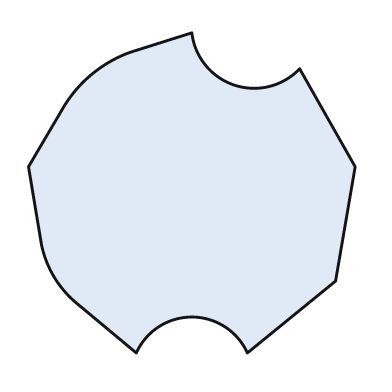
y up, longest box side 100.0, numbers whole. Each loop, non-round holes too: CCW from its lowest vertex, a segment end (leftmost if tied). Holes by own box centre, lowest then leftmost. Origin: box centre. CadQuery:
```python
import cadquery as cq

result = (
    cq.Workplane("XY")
    .moveTo(-17.0, -49.0)
    .threePointArc((0.0, -38.0), (17.0, -49.0))
    .lineTo(44.0, -27.0)
    .lineTo(50.0, 8.0)
    .lineTo(33.0, 38.0)
    .threePointArc((13.0, 33.0), (0.0, 49.0))
    .lineTo(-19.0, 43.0)
    .threePointArc((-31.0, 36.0), (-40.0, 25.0))
    .lineTo(-50.0, 8.0)
    .lineTo(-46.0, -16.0)
    .threePointArc((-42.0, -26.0), (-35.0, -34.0))
    .close()
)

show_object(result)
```